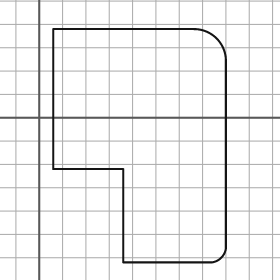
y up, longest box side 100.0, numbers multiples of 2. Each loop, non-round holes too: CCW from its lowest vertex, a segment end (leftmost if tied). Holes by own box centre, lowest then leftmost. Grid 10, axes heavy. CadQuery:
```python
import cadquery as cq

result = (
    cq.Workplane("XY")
    .moveTo(36.0, -62.0)
    .lineTo(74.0, -62.0)
    .threePointArc((78.0, -60.0), (80.0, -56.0))
    .lineTo(80.0, 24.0)
    .threePointArc((76.0, 34.0), (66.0, 38.0))
    .lineTo(6.0, 38.0)
    .lineTo(6.0, -22.0)
    .lineTo(36.0, -22.0)
    .close()
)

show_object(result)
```